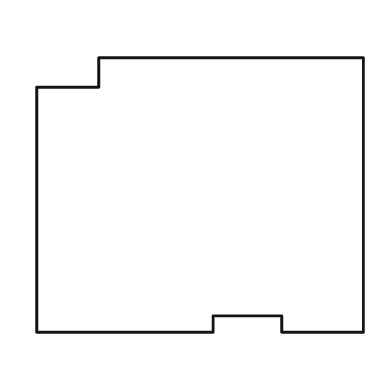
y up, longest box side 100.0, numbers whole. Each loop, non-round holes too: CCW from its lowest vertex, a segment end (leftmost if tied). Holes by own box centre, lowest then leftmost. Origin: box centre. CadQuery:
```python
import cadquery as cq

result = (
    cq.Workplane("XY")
    .moveTo(-50.0, -42.0)
    .lineTo(4.0, -42.0)
    .lineTo(4.0, -37.0)
    .lineTo(25.0, -37.0)
    .lineTo(25.0, -42.0)
    .lineTo(50.0, -42.0)
    .lineTo(50.0, 42.0)
    .lineTo(-31.0, 42.0)
    .lineTo(-31.0, 33.0)
    .lineTo(-50.0, 33.0)
    .close()
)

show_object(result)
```